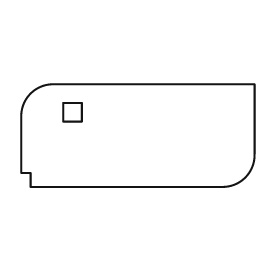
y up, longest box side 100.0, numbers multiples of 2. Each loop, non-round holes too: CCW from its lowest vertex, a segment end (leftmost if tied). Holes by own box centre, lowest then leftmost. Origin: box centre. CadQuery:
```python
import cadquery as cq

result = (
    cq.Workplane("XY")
    .moveTo(-46.0, -22.0)
    .lineTo(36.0, -22.0)
    .threePointArc((46.0, -18.0), (50.0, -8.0))
    .lineTo(50.0, 22.0)
    .lineTo(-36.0, 22.0)
    .threePointArc((-46.0, 18.0), (-50.0, 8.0))
    .lineTo(-50.0, -16.0)
    .lineTo(-46.0, -16.0)
    .close()
    .moveTo(-32.0, 6.0)
    .lineTo(-24.0, 6.0)
    .lineTo(-24.0, 14.0)
    .lineTo(-32.0, 14.0)
    .close()
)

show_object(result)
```